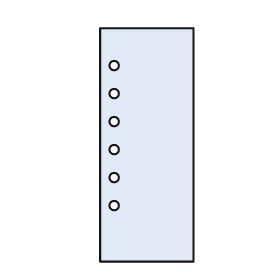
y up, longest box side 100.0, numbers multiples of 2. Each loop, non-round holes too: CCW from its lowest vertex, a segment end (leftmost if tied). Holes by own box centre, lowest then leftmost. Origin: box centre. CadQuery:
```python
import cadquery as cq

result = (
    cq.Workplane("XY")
    .moveTo(-20.0, -50.0)
    .lineTo(20.0, -50.0)
    .lineTo(20.0, 50.0)
    .lineTo(-20.0, 50.0)
    .close()
    .moveTo(-14.0, -26.0)
    .circle(2.0)
    .moveTo(-14.0, -14.0)
    .circle(2.0)
    .moveTo(-14.0, -2.0)
    .circle(2.0)
    .moveTo(-14.0, 10.0)
    .circle(2.0)
    .moveTo(-14.0, 22.0)
    .circle(2.0)
    .moveTo(-14.0, 34.0)
    .circle(2.0)
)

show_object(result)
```